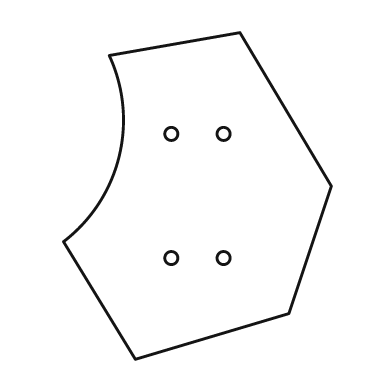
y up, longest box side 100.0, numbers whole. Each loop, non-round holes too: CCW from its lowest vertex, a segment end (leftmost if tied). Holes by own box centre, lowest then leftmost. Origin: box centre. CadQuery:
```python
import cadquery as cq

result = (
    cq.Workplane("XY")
    .moveTo(-19.0, -50.0)
    .lineTo(28.0, -36.0)
    .lineTo(41.0, 3.0)
    .lineTo(13.0, 50.0)
    .lineTo(-27.0, 43.0)
    .threePointArc((-24.0, 12.0), (-41.0, -14.0))
    .close()
    .moveTo(-8.0, -19.0)
    .circle(2.0)
    .moveTo(8.0, -19.0)
    .circle(2.0)
    .moveTo(-8.0, 19.0)
    .circle(2.0)
    .moveTo(8.0, 19.0)
    .circle(2.0)
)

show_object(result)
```